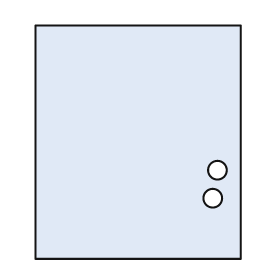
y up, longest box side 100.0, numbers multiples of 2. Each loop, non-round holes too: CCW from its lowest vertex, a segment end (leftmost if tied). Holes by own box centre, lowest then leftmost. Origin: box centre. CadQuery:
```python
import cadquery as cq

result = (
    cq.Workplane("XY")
    .moveTo(-44.0, -50.0)
    .lineTo(44.0, -50.0)
    .lineTo(44.0, 50.0)
    .lineTo(-44.0, 50.0)
    .close()
    .moveTo(32.0, -24.0)
    .circle(4.0)
    .moveTo(34.0, -12.0)
    .circle(4.0)
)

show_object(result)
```